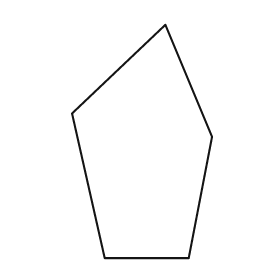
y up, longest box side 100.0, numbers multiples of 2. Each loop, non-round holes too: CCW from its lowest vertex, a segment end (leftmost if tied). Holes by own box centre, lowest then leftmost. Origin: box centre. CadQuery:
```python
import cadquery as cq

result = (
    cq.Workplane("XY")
    .moveTo(-16.0, -50.0)
    .lineTo(20.0, -50.0)
    .lineTo(30.0, 2.0)
    .lineTo(10.0, 50.0)
    .lineTo(-30.0, 12.0)
    .close()
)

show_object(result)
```